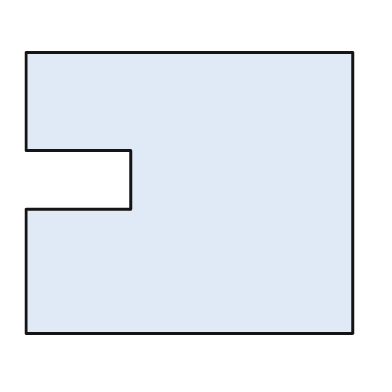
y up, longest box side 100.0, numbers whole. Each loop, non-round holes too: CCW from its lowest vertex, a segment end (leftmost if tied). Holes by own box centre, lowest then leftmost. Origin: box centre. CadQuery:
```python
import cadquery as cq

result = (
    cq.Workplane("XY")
    .moveTo(-50.0, -43.0)
    .lineTo(50.0, -43.0)
    .lineTo(50.0, 43.0)
    .lineTo(-50.0, 43.0)
    .lineTo(-50.0, 13.0)
    .lineTo(-18.0, 13.0)
    .lineTo(-18.0, -5.0)
    .lineTo(-50.0, -5.0)
    .close()
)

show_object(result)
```